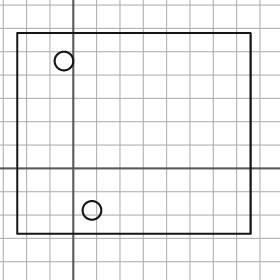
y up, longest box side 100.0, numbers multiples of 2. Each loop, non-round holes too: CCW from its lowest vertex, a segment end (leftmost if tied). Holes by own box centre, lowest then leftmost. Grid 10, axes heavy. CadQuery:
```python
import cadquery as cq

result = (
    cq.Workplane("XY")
    .moveTo(-24.0, -28.0)
    .lineTo(76.0, -28.0)
    .lineTo(76.0, 58.0)
    .lineTo(-24.0, 58.0)
    .close()
    .moveTo(8.0, -18.0)
    .circle(4.0)
    .moveTo(-4.0, 46.0)
    .circle(4.0)
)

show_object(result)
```